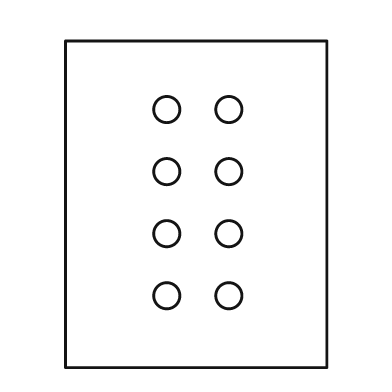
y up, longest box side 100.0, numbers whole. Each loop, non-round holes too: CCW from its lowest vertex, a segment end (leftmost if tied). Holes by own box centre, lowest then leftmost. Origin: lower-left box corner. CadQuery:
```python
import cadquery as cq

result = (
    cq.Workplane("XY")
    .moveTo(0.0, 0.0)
    .lineTo(80.0, 0.0)
    .lineTo(80.0, 100.0)
    .lineTo(0.0, 100.0)
    .close()
    .moveTo(31.0, 22.0)
    .circle(4.0)
    .moveTo(50.0, 22.0)
    .circle(4.0)
    .moveTo(31.0, 41.0)
    .circle(4.0)
    .moveTo(50.0, 41.0)
    .circle(4.0)
    .moveTo(31.0, 60.0)
    .circle(4.0)
    .moveTo(50.0, 60.0)
    .circle(4.0)
    .moveTo(31.0, 79.0)
    .circle(4.0)
    .moveTo(50.0, 79.0)
    .circle(4.0)
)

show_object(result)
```